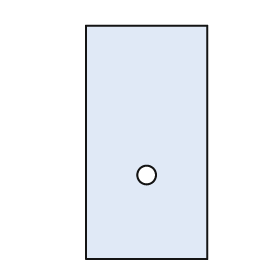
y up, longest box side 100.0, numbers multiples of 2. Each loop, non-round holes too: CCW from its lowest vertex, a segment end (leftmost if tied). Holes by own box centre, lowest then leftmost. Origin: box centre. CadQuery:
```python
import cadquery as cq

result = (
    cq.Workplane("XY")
    .moveTo(-26.0, -50.0)
    .lineTo(26.0, -50.0)
    .lineTo(26.0, 50.0)
    .lineTo(-26.0, 50.0)
    .close()
    .moveTo(0.0, -14.0)
    .circle(4.0)
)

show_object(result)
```